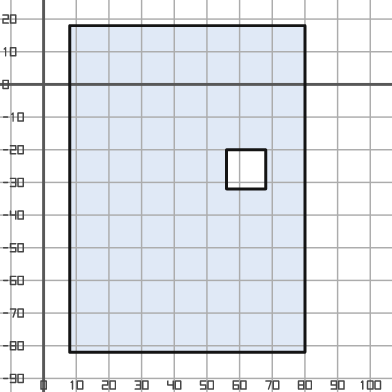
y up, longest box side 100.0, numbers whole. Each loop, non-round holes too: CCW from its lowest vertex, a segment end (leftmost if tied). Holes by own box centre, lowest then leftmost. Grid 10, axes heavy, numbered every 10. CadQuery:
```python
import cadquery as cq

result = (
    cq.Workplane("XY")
    .moveTo(8.0, -82.0)
    .lineTo(80.0, -82.0)
    .lineTo(80.0, 18.0)
    .lineTo(8.0, 18.0)
    .close()
    .moveTo(56.0, -32.0)
    .lineTo(68.0, -32.0)
    .lineTo(68.0, -20.0)
    .lineTo(56.0, -20.0)
    .close()
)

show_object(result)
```